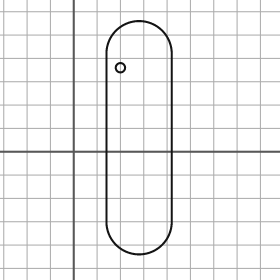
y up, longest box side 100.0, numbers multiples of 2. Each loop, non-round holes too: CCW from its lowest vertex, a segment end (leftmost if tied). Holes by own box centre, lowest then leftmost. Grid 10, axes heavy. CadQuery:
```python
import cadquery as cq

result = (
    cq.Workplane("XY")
    .moveTo(14.0, -30.0)
    .threePointArc((28.0, -44.0), (42.0, -30.0))
    .lineTo(42.0, 42.0)
    .threePointArc((28.0, 56.0), (14.0, 42.0))
    .close()
    .moveTo(20.0, 36.0)
    .circle(2.0)
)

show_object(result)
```